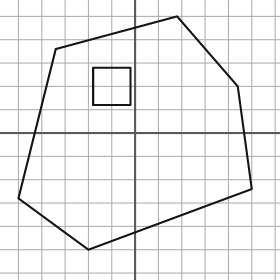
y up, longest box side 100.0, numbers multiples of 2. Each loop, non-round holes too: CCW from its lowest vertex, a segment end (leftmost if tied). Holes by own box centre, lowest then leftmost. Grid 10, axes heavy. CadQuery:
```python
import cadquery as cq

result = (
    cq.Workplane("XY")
    .moveTo(-20.0, -50.0)
    .lineTo(50.0, -24.0)
    .lineTo(44.0, 20.0)
    .lineTo(18.0, 50.0)
    .lineTo(-34.0, 36.0)
    .lineTo(-50.0, -28.0)
    .close()
    .moveTo(-18.0, 12.0)
    .lineTo(-2.0, 12.0)
    .lineTo(-2.0, 28.0)
    .lineTo(-18.0, 28.0)
    .close()
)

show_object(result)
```